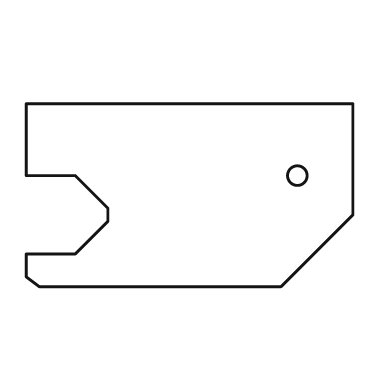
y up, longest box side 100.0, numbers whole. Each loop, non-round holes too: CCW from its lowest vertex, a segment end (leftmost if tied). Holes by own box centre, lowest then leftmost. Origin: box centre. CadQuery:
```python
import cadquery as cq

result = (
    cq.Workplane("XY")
    .moveTo(-46.0, -28.0)
    .lineTo(28.0, -28.0)
    .lineTo(50.0, -6.0)
    .lineTo(50.0, 28.0)
    .lineTo(-50.0, 28.0)
    .lineTo(-50.0, 6.0)
    .lineTo(-35.0, 6.0)
    .lineTo(-25.0, -4.0)
    .lineTo(-25.0, -8.0)
    .lineTo(-35.0, -18.0)
    .lineTo(-50.0, -18.0)
    .lineTo(-50.0, -25.0)
    .close()
    .moveTo(33.0, 6.0)
    .circle(3.0)
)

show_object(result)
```